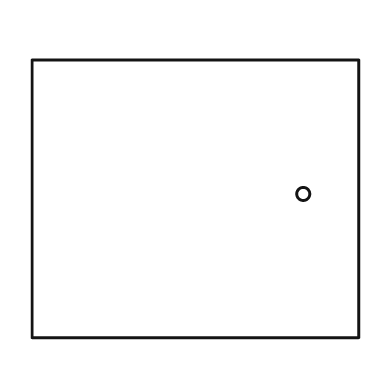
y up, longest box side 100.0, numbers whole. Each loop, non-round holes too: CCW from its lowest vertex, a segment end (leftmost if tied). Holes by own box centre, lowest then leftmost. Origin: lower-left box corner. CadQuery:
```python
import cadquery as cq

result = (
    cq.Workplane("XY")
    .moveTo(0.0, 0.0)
    .lineTo(100.0, 0.0)
    .lineTo(100.0, 85.0)
    .lineTo(0.0, 85.0)
    .close()
    .moveTo(83.0, 44.0)
    .circle(2.0)
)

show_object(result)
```